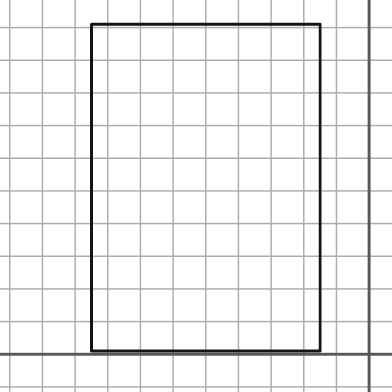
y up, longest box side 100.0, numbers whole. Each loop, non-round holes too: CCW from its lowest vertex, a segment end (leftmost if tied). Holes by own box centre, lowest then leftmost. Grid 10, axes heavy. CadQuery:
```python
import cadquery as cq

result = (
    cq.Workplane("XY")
    .moveTo(-85.0, 1.0)
    .lineTo(-15.0, 1.0)
    .lineTo(-15.0, 101.0)
    .lineTo(-85.0, 101.0)
    .close()
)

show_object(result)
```